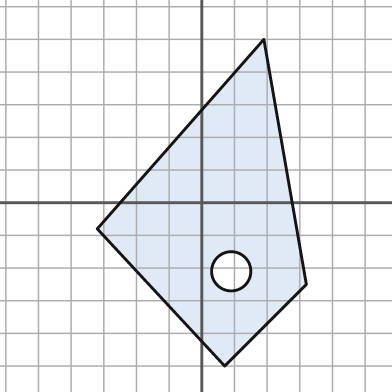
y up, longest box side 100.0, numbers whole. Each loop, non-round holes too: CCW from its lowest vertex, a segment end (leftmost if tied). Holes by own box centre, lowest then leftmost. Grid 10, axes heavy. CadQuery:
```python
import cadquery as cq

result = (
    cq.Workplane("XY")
    .moveTo(7.0, -50.0)
    .lineTo(32.0, -25.0)
    .lineTo(19.0, 50.0)
    .lineTo(-32.0, -8.0)
    .close()
    .moveTo(9.0, -21.0)
    .circle(6.0)
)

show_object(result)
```